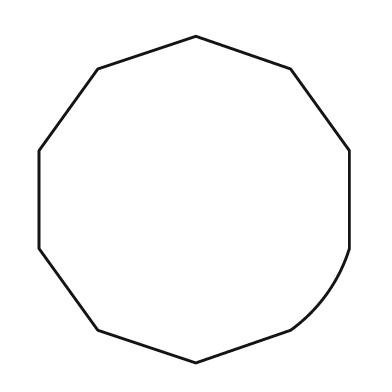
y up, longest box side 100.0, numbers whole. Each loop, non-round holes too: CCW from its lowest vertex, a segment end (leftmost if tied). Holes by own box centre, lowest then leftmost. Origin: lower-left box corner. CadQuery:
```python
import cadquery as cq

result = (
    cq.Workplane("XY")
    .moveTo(48.0, 0.0)
    .lineTo(77.0, 10.0)
    .threePointArc((88.0, 21.0), (95.0, 35.0))
    .lineTo(95.0, 65.0)
    .lineTo(77.0, 90.0)
    .lineTo(48.0, 100.0)
    .lineTo(18.0, 90.0)
    .lineTo(0.0, 65.0)
    .lineTo(0.0, 35.0)
    .lineTo(18.0, 10.0)
    .close()
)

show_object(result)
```